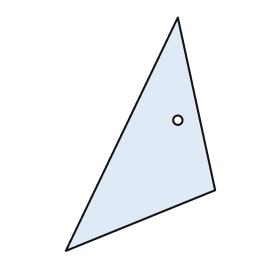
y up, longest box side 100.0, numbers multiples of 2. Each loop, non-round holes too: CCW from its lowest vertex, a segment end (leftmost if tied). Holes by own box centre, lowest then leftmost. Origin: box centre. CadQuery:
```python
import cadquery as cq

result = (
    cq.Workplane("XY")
    .moveTo(-32.0, -50.0)
    .lineTo(32.0, -24.0)
    .lineTo(16.0, 50.0)
    .close()
    .moveTo(16.0, 6.0)
    .circle(2.0)
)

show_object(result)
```